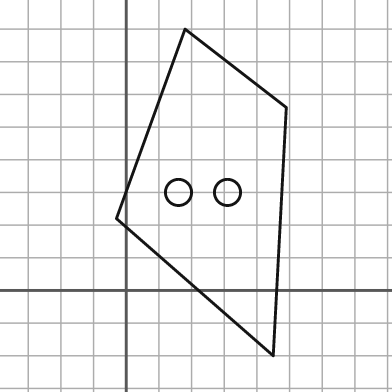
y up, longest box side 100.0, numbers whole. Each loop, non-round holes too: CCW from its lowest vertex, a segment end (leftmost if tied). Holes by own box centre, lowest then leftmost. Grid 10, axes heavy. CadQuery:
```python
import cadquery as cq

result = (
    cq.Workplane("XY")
    .moveTo(45.0, -20.0)
    .lineTo(49.0, 56.0)
    .lineTo(18.0, 80.0)
    .lineTo(-3.0, 22.0)
    .close()
    .moveTo(16.0, 30.0)
    .circle(4.0)
    .moveTo(31.0, 30.0)
    .circle(4.0)
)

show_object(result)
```